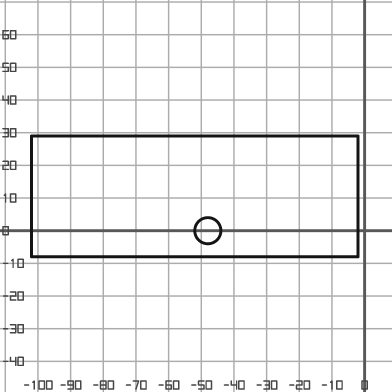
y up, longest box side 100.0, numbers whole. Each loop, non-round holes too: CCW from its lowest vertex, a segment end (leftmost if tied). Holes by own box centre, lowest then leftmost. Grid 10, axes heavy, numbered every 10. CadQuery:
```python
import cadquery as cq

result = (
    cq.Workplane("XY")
    .moveTo(-102.0, -8.0)
    .lineTo(-2.0, -8.0)
    .lineTo(-2.0, 29.0)
    .lineTo(-102.0, 29.0)
    .close()
    .moveTo(-48.0, 0.0)
    .circle(4.0)
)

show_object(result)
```